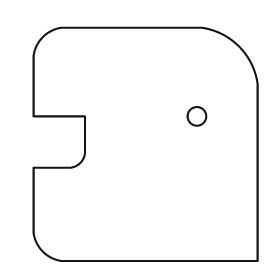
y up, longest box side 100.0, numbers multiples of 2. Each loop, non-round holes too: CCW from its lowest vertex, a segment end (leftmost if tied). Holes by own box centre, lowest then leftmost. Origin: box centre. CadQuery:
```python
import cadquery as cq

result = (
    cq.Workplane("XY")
    .moveTo(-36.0, -50.0)
    .lineTo(48.0, -50.0)
    .lineTo(48.0, 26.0)
    .threePointArc((40.0, 42.0), (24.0, 50.0))
    .lineTo(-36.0, 50.0)
    .threePointArc((-44.0, 46.0), (-48.0, 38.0))
    .lineTo(-48.0, 12.0)
    .lineTo(-26.0, 12.0)
    .lineTo(-26.0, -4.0)
    .threePointArc((-28.0, -8.0), (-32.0, -10.0))
    .lineTo(-48.0, -10.0)
    .lineTo(-48.0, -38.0)
    .threePointArc((-44.0, -46.0), (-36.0, -50.0))
    .close()
    .moveTo(22.0, 12.0)
    .circle(4.0)
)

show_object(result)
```